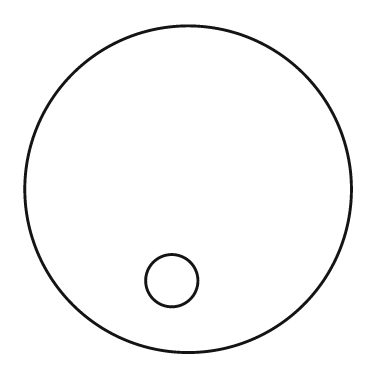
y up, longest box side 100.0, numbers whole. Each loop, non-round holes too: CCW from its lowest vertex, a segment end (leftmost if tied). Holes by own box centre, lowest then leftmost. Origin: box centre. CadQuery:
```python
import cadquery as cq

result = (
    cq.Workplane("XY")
    .moveTo(0.0, 0.0)
    .circle(50.0)
    .moveTo(-5.0, -28.0)
    .circle(8.0)
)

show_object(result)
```